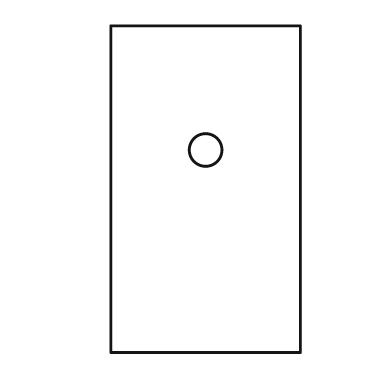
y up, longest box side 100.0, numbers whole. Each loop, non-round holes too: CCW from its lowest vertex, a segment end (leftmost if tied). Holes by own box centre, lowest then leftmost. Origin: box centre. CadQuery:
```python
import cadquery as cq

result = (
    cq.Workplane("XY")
    .moveTo(-29.0, -50.0)
    .lineTo(29.0, -50.0)
    .lineTo(29.0, 50.0)
    .lineTo(-29.0, 50.0)
    .close()
    .moveTo(0.0, 12.0)
    .circle(5.0)
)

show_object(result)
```